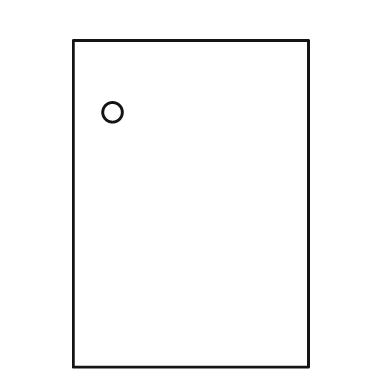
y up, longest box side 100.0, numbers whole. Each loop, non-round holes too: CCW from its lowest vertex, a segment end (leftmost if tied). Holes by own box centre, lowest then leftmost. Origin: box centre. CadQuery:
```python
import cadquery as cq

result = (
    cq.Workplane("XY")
    .moveTo(-36.0, -50.0)
    .lineTo(36.0, -50.0)
    .lineTo(36.0, 50.0)
    .lineTo(-36.0, 50.0)
    .close()
    .moveTo(-24.0, 28.0)
    .circle(3.0)
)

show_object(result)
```